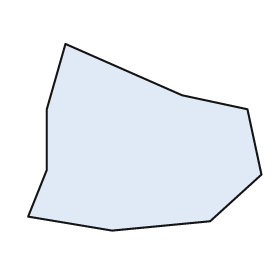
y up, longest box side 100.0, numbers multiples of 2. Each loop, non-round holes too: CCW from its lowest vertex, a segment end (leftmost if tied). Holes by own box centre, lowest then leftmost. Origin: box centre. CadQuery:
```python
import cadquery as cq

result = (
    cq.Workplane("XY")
    .moveTo(-14.0, -40.0)
    .lineTo(28.0, -36.0)
    .lineTo(50.0, -16.0)
    .lineTo(44.0, 12.0)
    .lineTo(16.0, 18.0)
    .lineTo(-34.0, 40.0)
    .lineTo(-42.0, 12.0)
    .lineTo(-42.0, -14.0)
    .lineTo(-50.0, -34.0)
    .close()
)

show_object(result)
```